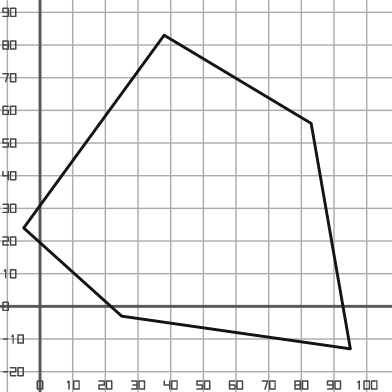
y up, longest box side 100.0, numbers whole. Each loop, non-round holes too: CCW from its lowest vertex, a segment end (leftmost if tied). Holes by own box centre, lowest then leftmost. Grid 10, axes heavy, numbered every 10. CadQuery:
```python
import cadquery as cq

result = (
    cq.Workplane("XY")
    .moveTo(95.0, -13.0)
    .lineTo(83.0, 56.0)
    .lineTo(38.0, 83.0)
    .lineTo(-5.0, 24.0)
    .lineTo(25.0, -3.0)
    .close()
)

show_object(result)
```